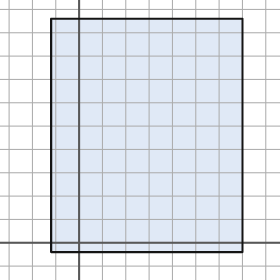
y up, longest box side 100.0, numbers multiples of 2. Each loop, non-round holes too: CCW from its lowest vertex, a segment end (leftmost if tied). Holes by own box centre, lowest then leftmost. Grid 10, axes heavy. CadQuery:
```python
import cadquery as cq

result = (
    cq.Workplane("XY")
    .moveTo(-12.0, -4.0)
    .lineTo(70.0, -4.0)
    .lineTo(70.0, 96.0)
    .lineTo(-12.0, 96.0)
    .close()
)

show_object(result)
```